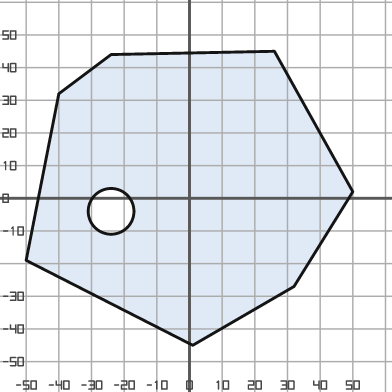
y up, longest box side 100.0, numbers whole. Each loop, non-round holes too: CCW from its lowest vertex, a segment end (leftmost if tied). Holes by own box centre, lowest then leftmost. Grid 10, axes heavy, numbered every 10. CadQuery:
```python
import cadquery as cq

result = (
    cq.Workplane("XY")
    .moveTo(1.0, -45.0)
    .lineTo(32.0, -27.0)
    .lineTo(50.0, 2.0)
    .lineTo(26.0, 45.0)
    .lineTo(-24.0, 44.0)
    .lineTo(-40.0, 32.0)
    .lineTo(-50.0, -19.0)
    .close()
    .moveTo(-24.0, -4.0)
    .circle(7.0)
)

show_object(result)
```